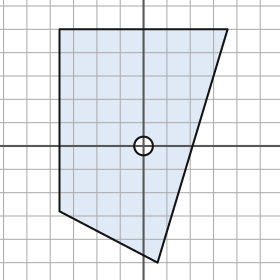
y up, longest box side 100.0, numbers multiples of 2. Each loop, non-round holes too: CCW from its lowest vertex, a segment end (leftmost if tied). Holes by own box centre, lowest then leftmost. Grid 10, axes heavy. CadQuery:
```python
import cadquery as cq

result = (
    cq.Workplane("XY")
    .moveTo(6.0, -50.0)
    .lineTo(36.0, 50.0)
    .lineTo(-36.0, 50.0)
    .lineTo(-36.0, -28.0)
    .close()
    .moveTo(0.0, 0.0)
    .circle(4.0)
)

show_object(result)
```